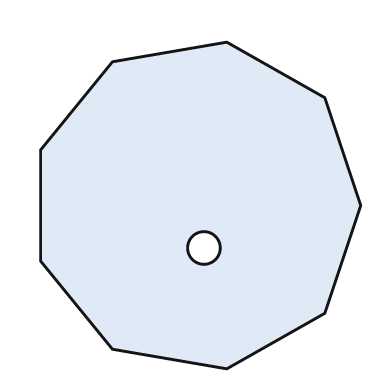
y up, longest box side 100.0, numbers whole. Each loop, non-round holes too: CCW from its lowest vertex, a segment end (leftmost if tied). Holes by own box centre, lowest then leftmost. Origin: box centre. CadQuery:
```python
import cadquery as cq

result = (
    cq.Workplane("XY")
    .moveTo(8.0, -50.0)
    .lineTo(38.0, -33.0)
    .lineTo(49.0, 0.0)
    .lineTo(38.0, 33.0)
    .lineTo(8.0, 50.0)
    .lineTo(-27.0, 44.0)
    .lineTo(-49.0, 17.0)
    .lineTo(-49.0, -17.0)
    .lineTo(-27.0, -44.0)
    .close()
    .moveTo(1.0, -13.0)
    .circle(5.0)
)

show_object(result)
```